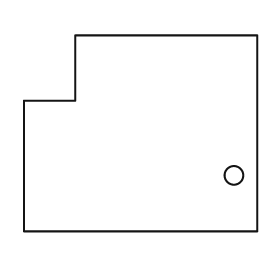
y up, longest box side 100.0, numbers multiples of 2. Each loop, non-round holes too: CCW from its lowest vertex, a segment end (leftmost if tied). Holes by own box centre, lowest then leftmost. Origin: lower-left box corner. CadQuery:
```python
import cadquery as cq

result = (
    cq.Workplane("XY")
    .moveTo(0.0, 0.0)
    .lineTo(100.0, 0.0)
    .lineTo(100.0, 84.0)
    .lineTo(22.0, 84.0)
    .lineTo(22.0, 56.0)
    .lineTo(0.0, 56.0)
    .close()
    .moveTo(90.0, 24.0)
    .circle(4.0)
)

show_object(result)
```